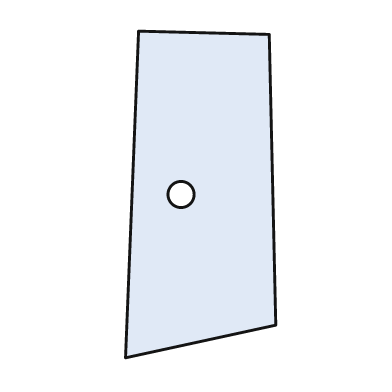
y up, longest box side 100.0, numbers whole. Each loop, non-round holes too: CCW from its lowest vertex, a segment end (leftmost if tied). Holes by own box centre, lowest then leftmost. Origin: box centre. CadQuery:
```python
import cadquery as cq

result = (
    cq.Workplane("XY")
    .moveTo(-23.0, -50.0)
    .lineTo(23.0, -40.0)
    .lineTo(21.0, 49.0)
    .lineTo(-19.0, 50.0)
    .close()
    .moveTo(-6.0, 0.0)
    .circle(4.0)
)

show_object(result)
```